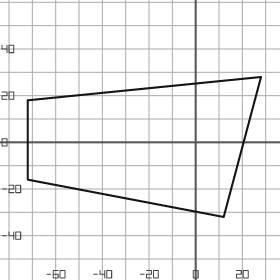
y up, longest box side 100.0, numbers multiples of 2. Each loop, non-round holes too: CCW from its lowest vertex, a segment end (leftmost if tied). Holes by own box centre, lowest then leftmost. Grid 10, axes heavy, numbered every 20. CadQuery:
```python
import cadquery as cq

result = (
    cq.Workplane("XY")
    .moveTo(12.0, -32.0)
    .lineTo(28.0, 28.0)
    .lineTo(-72.0, 18.0)
    .lineTo(-72.0, -16.0)
    .close()
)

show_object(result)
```